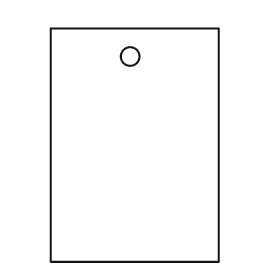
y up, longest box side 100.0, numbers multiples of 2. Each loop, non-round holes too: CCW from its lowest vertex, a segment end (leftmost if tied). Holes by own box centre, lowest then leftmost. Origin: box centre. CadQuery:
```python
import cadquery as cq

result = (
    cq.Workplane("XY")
    .moveTo(-36.0, -50.0)
    .lineTo(36.0, -50.0)
    .lineTo(36.0, 50.0)
    .lineTo(-36.0, 50.0)
    .close()
    .moveTo(-2.0, 38.0)
    .circle(4.0)
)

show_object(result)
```